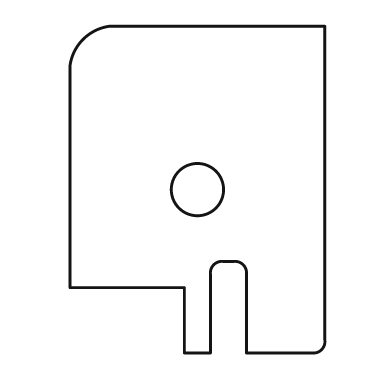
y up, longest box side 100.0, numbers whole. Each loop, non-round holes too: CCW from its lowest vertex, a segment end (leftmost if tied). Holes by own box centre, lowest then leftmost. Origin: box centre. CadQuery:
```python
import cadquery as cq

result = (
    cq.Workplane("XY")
    .moveTo(-4.0, -50.0)
    .lineTo(4.0, -50.0)
    .lineTo(4.0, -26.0)
    .threePointArc((5.0, -23.0), (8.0, -22.0))
    .lineTo(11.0, -22.0)
    .threePointArc((14.0, -23.0), (15.0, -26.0))
    .lineTo(15.0, -50.0)
    .lineTo(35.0, -50.0)
    .threePointArc((38.0, -49.0), (39.0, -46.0))
    .lineTo(39.0, 50.0)
    .lineTo(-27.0, 50.0)
    .threePointArc((-35.0, 46.0), (-39.0, 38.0))
    .lineTo(-39.0, -30.0)
    .lineTo(-4.0, -30.0)
    .close()
    .moveTo(0.0, 0.0)
    .circle(8.0)
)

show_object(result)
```